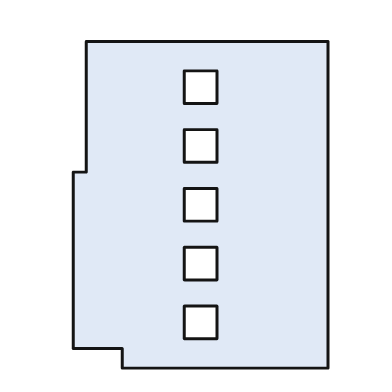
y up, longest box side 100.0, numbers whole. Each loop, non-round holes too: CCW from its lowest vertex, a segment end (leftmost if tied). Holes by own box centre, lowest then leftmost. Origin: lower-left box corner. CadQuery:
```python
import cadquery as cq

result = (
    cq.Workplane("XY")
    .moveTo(15.0, 0.0)
    .lineTo(78.0, 0.0)
    .lineTo(78.0, 100.0)
    .lineTo(4.0, 100.0)
    .lineTo(4.0, 60.0)
    .lineTo(0.0, 60.0)
    .lineTo(0.0, 6.0)
    .lineTo(15.0, 6.0)
    .close()
    .moveTo(34.0, 9.0)
    .lineTo(44.0, 9.0)
    .lineTo(44.0, 19.0)
    .lineTo(34.0, 19.0)
    .close()
    .moveTo(34.0, 27.0)
    .lineTo(44.0, 27.0)
    .lineTo(44.0, 37.0)
    .lineTo(34.0, 37.0)
    .close()
    .moveTo(34.0, 45.0)
    .lineTo(44.0, 45.0)
    .lineTo(44.0, 55.0)
    .lineTo(34.0, 55.0)
    .close()
    .moveTo(34.0, 63.0)
    .lineTo(44.0, 63.0)
    .lineTo(44.0, 73.0)
    .lineTo(34.0, 73.0)
    .close()
    .moveTo(34.0, 81.0)
    .lineTo(44.0, 81.0)
    .lineTo(44.0, 91.0)
    .lineTo(34.0, 91.0)
    .close()
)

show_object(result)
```